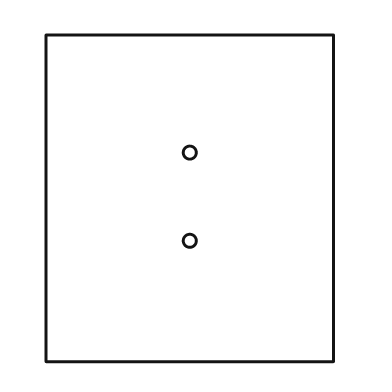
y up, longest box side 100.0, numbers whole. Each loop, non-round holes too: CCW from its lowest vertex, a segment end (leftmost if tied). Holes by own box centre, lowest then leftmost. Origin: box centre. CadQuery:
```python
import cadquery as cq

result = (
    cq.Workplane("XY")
    .moveTo(-44.0, -50.0)
    .lineTo(44.0, -50.0)
    .lineTo(44.0, 50.0)
    .lineTo(-44.0, 50.0)
    .close()
    .moveTo(0.0, -13.0)
    .circle(2.0)
    .moveTo(0.0, 14.0)
    .circle(2.0)
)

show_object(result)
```